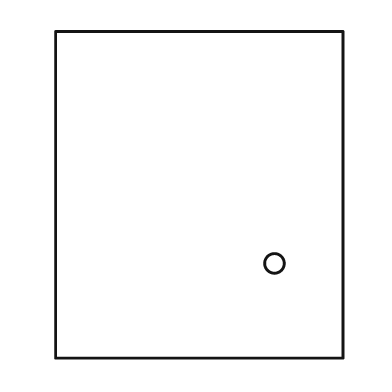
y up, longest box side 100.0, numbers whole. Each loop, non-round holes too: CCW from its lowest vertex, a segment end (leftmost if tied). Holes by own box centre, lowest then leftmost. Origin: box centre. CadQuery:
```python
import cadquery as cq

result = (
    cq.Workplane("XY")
    .moveTo(-44.0, -50.0)
    .lineTo(44.0, -50.0)
    .lineTo(44.0, 50.0)
    .lineTo(-44.0, 50.0)
    .close()
    .moveTo(23.0, -21.0)
    .circle(3.0)
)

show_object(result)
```